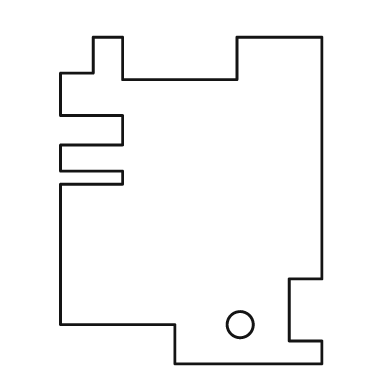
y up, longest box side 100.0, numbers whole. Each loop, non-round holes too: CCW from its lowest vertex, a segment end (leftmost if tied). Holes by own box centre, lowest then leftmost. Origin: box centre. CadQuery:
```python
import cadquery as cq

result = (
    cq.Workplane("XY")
    .moveTo(-5.0, -50.0)
    .lineTo(40.0, -50.0)
    .lineTo(40.0, -43.0)
    .lineTo(30.0, -43.0)
    .lineTo(30.0, -24.0)
    .lineTo(40.0, -24.0)
    .lineTo(40.0, 50.0)
    .lineTo(14.0, 50.0)
    .lineTo(14.0, 37.0)
    .lineTo(-21.0, 37.0)
    .lineTo(-21.0, 50.0)
    .lineTo(-30.0, 50.0)
    .lineTo(-30.0, 39.0)
    .lineTo(-40.0, 39.0)
    .lineTo(-40.0, 26.0)
    .lineTo(-21.0, 26.0)
    .lineTo(-21.0, 17.0)
    .lineTo(-40.0, 17.0)
    .lineTo(-40.0, 9.0)
    .lineTo(-21.0, 9.0)
    .lineTo(-21.0, 5.0)
    .lineTo(-40.0, 5.0)
    .lineTo(-40.0, -38.0)
    .lineTo(-5.0, -38.0)
    .close()
    .moveTo(15.0, -38.0)
    .circle(4.0)
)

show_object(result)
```